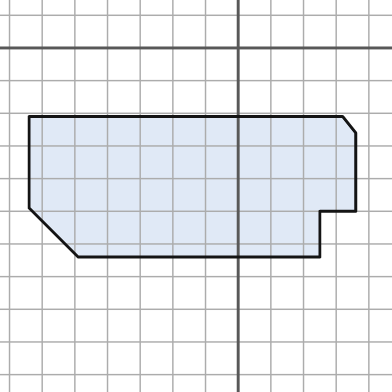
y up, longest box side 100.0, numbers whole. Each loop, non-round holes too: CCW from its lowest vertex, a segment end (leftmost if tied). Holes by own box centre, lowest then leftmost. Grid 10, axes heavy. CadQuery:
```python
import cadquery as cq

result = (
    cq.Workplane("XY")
    .moveTo(-49.0, -64.0)
    .lineTo(25.0, -64.0)
    .lineTo(25.0, -50.0)
    .lineTo(36.0, -50.0)
    .lineTo(36.0, -26.0)
    .lineTo(32.0, -21.0)
    .lineTo(-64.0, -21.0)
    .lineTo(-64.0, -49.0)
    .close()
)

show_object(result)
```